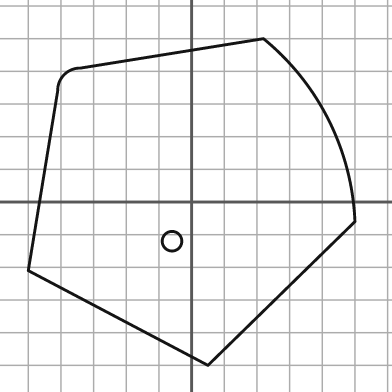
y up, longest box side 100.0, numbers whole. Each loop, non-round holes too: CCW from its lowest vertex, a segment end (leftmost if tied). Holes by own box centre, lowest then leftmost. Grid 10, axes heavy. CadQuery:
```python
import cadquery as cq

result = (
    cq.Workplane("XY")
    .moveTo(5.0, -50.0)
    .lineTo(50.0, -6.0)
    .threePointArc((42.0, 25.0), (22.0, 50.0))
    .lineTo(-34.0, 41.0)
    .threePointArc((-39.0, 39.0), (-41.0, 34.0))
    .lineTo(-50.0, -21.0)
    .close()
    .moveTo(-6.0, -12.0)
    .circle(3.0)
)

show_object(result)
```